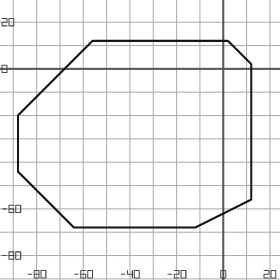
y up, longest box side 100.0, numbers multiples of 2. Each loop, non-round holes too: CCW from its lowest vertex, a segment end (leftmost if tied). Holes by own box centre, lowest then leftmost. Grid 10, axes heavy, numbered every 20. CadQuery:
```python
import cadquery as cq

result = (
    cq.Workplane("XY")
    .moveTo(-64.0, -68.0)
    .lineTo(-12.0, -68.0)
    .lineTo(12.0, -56.0)
    .lineTo(12.0, 2.0)
    .lineTo(2.0, 12.0)
    .lineTo(-56.0, 12.0)
    .lineTo(-88.0, -20.0)
    .lineTo(-88.0, -44.0)
    .close()
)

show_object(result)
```